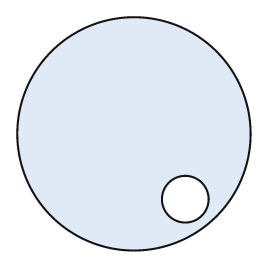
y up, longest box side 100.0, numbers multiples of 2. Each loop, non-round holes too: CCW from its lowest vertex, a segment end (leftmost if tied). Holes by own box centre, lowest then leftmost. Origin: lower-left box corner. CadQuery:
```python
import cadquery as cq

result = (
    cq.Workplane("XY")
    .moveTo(50.0, 50.0)
    .circle(50.0)
    .moveTo(72.0, 22.0)
    .circle(10.0)
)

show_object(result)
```